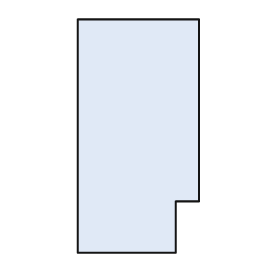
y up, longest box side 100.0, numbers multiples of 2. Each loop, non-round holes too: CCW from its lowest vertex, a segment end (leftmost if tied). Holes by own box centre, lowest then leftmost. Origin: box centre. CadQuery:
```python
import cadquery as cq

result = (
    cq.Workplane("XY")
    .moveTo(-26.0, -50.0)
    .lineTo(16.0, -50.0)
    .lineTo(16.0, -28.0)
    .lineTo(26.0, -28.0)
    .lineTo(26.0, 50.0)
    .lineTo(-26.0, 50.0)
    .close()
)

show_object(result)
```